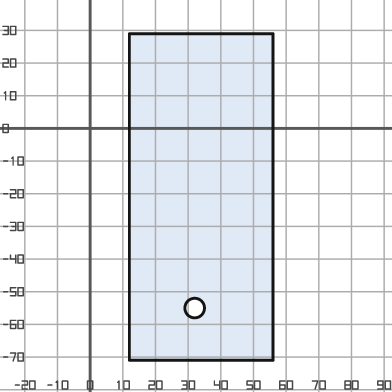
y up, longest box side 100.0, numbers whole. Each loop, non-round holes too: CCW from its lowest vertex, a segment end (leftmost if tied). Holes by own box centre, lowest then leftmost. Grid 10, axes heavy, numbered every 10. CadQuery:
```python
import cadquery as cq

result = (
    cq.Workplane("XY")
    .moveTo(12.0, -71.0)
    .lineTo(56.0, -71.0)
    .lineTo(56.0, 29.0)
    .lineTo(12.0, 29.0)
    .close()
    .moveTo(32.0, -55.0)
    .circle(3.0)
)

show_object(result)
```